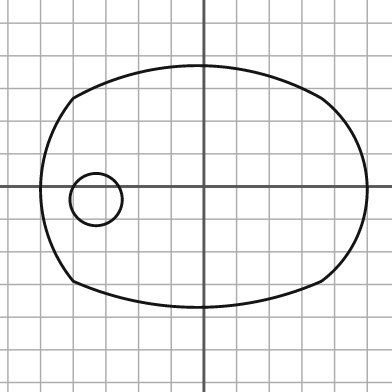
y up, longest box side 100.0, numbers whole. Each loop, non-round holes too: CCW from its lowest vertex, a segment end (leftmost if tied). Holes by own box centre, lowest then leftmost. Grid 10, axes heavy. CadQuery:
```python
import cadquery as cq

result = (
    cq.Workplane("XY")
    .moveTo(-40.0, -29.0)
    .threePointArc((-2.0, -37.0), (36.0, -29.0))
    .threePointArc((50.0, -1.0), (36.0, 27.0))
    .threePointArc((-2.0, 37.0), (-40.0, 27.0))
    .threePointArc((-50.0, -1.0), (-40.0, -29.0))
    .close()
    .moveTo(-33.0, -4.0)
    .circle(8.0)
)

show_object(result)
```